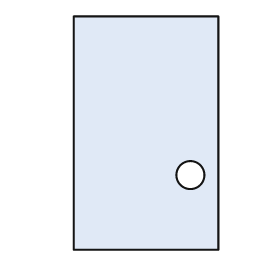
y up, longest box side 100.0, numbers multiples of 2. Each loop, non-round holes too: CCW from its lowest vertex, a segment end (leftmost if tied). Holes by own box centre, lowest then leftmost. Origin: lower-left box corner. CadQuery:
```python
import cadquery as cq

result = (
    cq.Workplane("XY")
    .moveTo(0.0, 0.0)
    .lineTo(62.0, 0.0)
    .lineTo(62.0, 100.0)
    .lineTo(0.0, 100.0)
    .close()
    .moveTo(50.0, 32.0)
    .circle(6.0)
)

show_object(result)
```